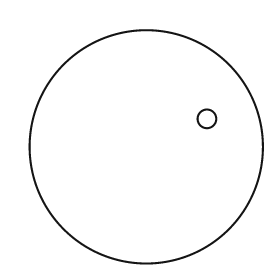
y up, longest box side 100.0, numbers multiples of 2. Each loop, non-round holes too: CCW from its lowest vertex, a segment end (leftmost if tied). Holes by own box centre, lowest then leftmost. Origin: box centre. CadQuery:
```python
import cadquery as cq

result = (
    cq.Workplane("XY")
    .moveTo(0.0, 0.0)
    .circle(50.0)
    .moveTo(26.0, 12.0)
    .circle(4.0)
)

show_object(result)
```